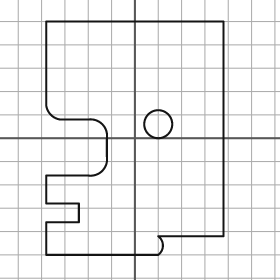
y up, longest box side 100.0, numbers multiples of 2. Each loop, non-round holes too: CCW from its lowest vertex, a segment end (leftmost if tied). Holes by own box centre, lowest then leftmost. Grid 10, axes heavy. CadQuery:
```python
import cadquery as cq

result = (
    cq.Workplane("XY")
    .moveTo(-38.0, -50.0)
    .lineTo(10.0, -50.0)
    .threePointArc((12.0, -46.0), (10.0, -42.0))
    .lineTo(38.0, -42.0)
    .lineTo(38.0, 50.0)
    .lineTo(-38.0, 50.0)
    .lineTo(-38.0, 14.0)
    .threePointArc((-36.0, 10.0), (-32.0, 8.0))
    .lineTo(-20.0, 8.0)
    .threePointArc((-14.0, 6.0), (-12.0, 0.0))
    .lineTo(-12.0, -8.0)
    .threePointArc((-14.0, -14.0), (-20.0, -16.0))
    .lineTo(-38.0, -16.0)
    .lineTo(-38.0, -28.0)
    .lineTo(-24.0, -28.0)
    .lineTo(-24.0, -36.0)
    .lineTo(-38.0, -36.0)
    .close()
    .moveTo(10.0, 6.0)
    .circle(6.0)
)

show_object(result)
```